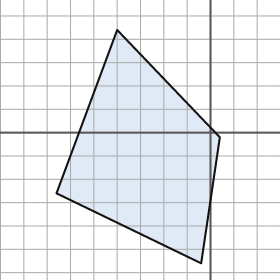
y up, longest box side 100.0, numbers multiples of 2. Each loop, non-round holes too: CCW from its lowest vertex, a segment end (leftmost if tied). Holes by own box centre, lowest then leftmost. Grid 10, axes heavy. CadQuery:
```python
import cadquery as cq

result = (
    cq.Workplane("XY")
    .moveTo(-4.0, -56.0)
    .lineTo(4.0, -2.0)
    .lineTo(-40.0, 44.0)
    .lineTo(-66.0, -26.0)
    .close()
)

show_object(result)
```